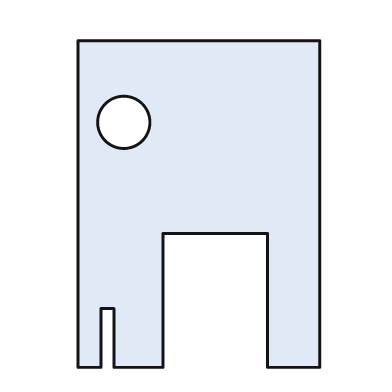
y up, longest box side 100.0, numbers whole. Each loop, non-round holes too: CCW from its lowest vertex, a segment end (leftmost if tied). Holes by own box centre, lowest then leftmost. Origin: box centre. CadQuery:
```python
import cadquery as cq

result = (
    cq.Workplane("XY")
    .moveTo(-37.0, -50.0)
    .lineTo(-30.0, -50.0)
    .lineTo(-30.0, -32.0)
    .lineTo(-26.0, -32.0)
    .lineTo(-26.0, -50.0)
    .lineTo(-11.0, -50.0)
    .lineTo(-11.0, -9.0)
    .lineTo(21.0, -9.0)
    .lineTo(21.0, -50.0)
    .lineTo(37.0, -50.0)
    .lineTo(37.0, 50.0)
    .lineTo(-37.0, 50.0)
    .close()
    .moveTo(-23.0, 25.0)
    .circle(8.0)
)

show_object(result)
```